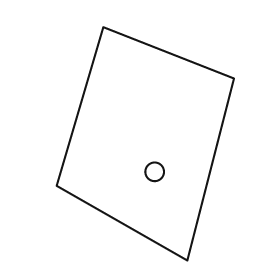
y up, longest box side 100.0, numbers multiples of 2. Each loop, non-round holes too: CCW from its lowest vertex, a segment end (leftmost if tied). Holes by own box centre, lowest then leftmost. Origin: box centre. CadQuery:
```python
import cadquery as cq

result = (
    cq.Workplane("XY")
    .moveTo(18.0, -50.0)
    .lineTo(38.0, 28.0)
    .lineTo(-18.0, 50.0)
    .lineTo(-38.0, -18.0)
    .close()
    .moveTo(4.0, -12.0)
    .circle(4.0)
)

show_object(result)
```